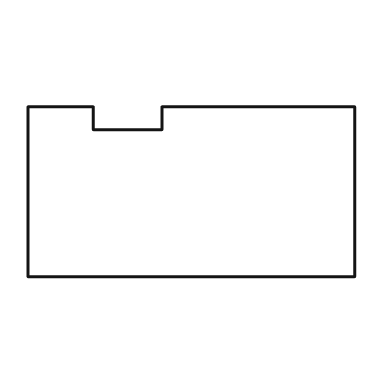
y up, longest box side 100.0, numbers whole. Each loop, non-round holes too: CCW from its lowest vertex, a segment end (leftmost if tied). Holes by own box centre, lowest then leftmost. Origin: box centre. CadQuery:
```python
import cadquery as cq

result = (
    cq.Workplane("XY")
    .moveTo(-50.0, -26.0)
    .lineTo(50.0, -26.0)
    .lineTo(50.0, 26.0)
    .lineTo(-9.0, 26.0)
    .lineTo(-9.0, 19.0)
    .lineTo(-30.0, 19.0)
    .lineTo(-30.0, 26.0)
    .lineTo(-50.0, 26.0)
    .close()
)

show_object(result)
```